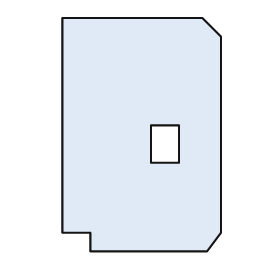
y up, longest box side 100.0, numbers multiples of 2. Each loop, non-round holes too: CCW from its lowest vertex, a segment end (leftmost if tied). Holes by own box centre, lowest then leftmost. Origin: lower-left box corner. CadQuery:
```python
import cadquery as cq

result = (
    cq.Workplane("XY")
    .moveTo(12.0, 0.0)
    .lineTo(62.0, 0.0)
    .lineTo(68.0, 8.0)
    .lineTo(68.0, 92.0)
    .lineTo(60.0, 100.0)
    .lineTo(0.0, 100.0)
    .lineTo(0.0, 8.0)
    .lineTo(12.0, 8.0)
    .close()
    .moveTo(38.0, 38.0)
    .lineTo(50.0, 38.0)
    .lineTo(50.0, 54.0)
    .lineTo(38.0, 54.0)
    .close()
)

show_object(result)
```